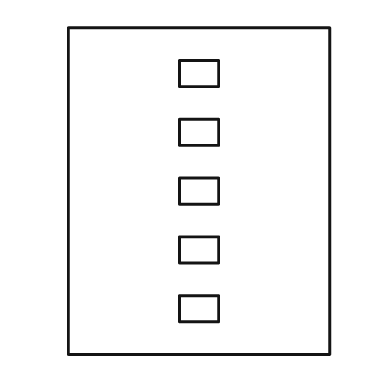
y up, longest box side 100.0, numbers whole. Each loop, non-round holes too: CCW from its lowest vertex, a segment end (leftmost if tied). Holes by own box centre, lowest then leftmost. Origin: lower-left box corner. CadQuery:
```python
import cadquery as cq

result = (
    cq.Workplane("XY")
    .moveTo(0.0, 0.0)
    .lineTo(80.0, 0.0)
    .lineTo(80.0, 100.0)
    .lineTo(0.0, 100.0)
    .close()
    .moveTo(34.0, 10.0)
    .lineTo(46.0, 10.0)
    .lineTo(46.0, 18.0)
    .lineTo(34.0, 18.0)
    .close()
    .moveTo(34.0, 28.0)
    .lineTo(46.0, 28.0)
    .lineTo(46.0, 36.0)
    .lineTo(34.0, 36.0)
    .close()
    .moveTo(34.0, 46.0)
    .lineTo(46.0, 46.0)
    .lineTo(46.0, 54.0)
    .lineTo(34.0, 54.0)
    .close()
    .moveTo(34.0, 64.0)
    .lineTo(46.0, 64.0)
    .lineTo(46.0, 72.0)
    .lineTo(34.0, 72.0)
    .close()
    .moveTo(34.0, 82.0)
    .lineTo(46.0, 82.0)
    .lineTo(46.0, 90.0)
    .lineTo(34.0, 90.0)
    .close()
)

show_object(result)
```